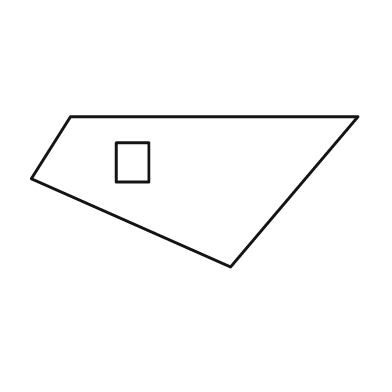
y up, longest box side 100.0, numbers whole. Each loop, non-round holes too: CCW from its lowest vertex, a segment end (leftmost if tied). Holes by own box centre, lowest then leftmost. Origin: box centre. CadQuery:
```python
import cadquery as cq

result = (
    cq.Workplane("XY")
    .moveTo(11.0, -23.0)
    .lineTo(50.0, 23.0)
    .lineTo(-38.0, 23.0)
    .lineTo(-50.0, 4.0)
    .close()
    .moveTo(-24.0, 3.0)
    .lineTo(-14.0, 3.0)
    .lineTo(-14.0, 15.0)
    .lineTo(-24.0, 15.0)
    .close()
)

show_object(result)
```